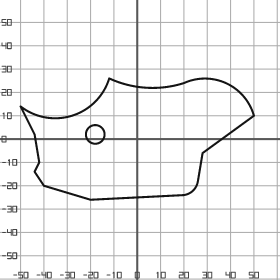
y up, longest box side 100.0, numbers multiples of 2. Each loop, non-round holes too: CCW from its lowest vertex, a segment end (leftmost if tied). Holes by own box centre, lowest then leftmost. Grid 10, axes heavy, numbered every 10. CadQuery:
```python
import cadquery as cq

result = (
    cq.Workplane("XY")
    .moveTo(-20.0, -26.0)
    .lineTo(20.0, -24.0)
    .threePointArc((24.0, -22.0), (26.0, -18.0))
    .lineTo(28.0, -6.0)
    .lineTo(50.0, 10.0)
    .threePointArc((38.0, 24.0), (20.0, 24.0))
    .threePointArc((4.0, 22.0), (-12.0, 26.0))
    .threePointArc((-28.0, 10.0), (-50.0, 14.0))
    .lineTo(-44.0, 2.0)
    .lineTo(-42.0, -10.0)
    .lineTo(-44.0, -14.0)
    .lineTo(-40.0, -20.0)
    .close()
    .moveTo(-18.0, 2.0)
    .circle(4.0)
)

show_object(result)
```